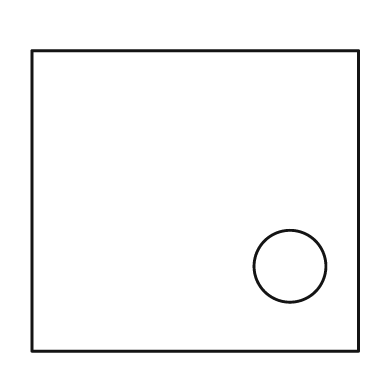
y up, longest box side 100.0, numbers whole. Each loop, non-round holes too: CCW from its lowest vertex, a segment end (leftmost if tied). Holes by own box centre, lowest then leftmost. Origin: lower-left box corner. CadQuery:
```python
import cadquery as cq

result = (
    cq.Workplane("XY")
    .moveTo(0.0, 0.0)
    .lineTo(100.0, 0.0)
    .lineTo(100.0, 92.0)
    .lineTo(0.0, 92.0)
    .close()
    .moveTo(79.0, 26.0)
    .circle(11.0)
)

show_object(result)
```